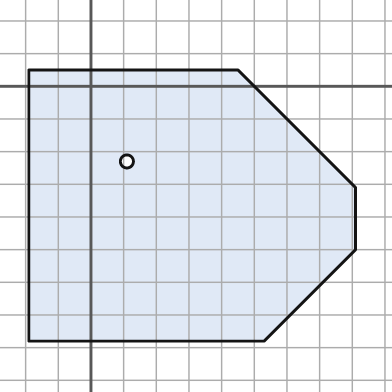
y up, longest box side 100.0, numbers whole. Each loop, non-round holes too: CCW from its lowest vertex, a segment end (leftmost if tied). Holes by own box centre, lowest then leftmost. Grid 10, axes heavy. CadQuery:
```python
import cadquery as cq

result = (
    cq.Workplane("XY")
    .moveTo(-19.0, -78.0)
    .lineTo(53.0, -78.0)
    .lineTo(81.0, -50.0)
    .lineTo(81.0, -31.0)
    .lineTo(45.0, 5.0)
    .lineTo(-19.0, 5.0)
    .close()
    .moveTo(11.0, -23.0)
    .circle(2.0)
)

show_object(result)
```